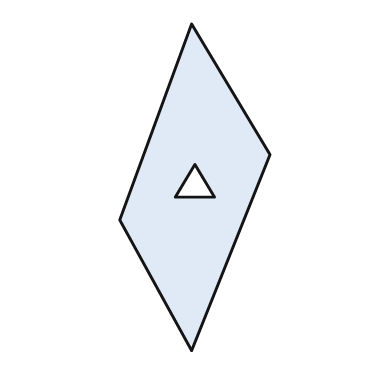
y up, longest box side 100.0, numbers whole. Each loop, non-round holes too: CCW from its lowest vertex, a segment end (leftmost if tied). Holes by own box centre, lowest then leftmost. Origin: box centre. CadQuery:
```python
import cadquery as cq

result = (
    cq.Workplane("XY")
    .moveTo(-1.0, -50.0)
    .lineTo(23.0, 10.0)
    .lineTo(-1.0, 50.0)
    .lineTo(-23.0, -10.0)
    .close()
    .moveTo(-6.0, -3.0)
    .lineTo(6.0, -3.0)
    .lineTo(0.0, 7.0)
    .close()
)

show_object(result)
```